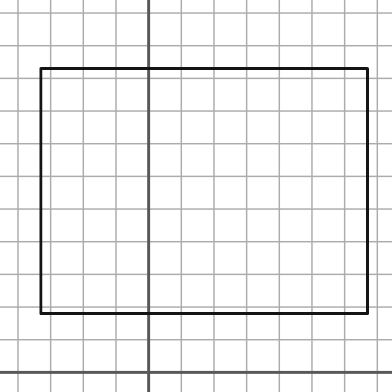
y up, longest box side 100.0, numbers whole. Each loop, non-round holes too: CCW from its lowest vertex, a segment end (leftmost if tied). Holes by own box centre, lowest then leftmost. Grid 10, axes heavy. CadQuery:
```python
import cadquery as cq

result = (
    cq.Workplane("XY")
    .moveTo(-33.0, 18.0)
    .lineTo(67.0, 18.0)
    .lineTo(67.0, 93.0)
    .lineTo(-33.0, 93.0)
    .close()
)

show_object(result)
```